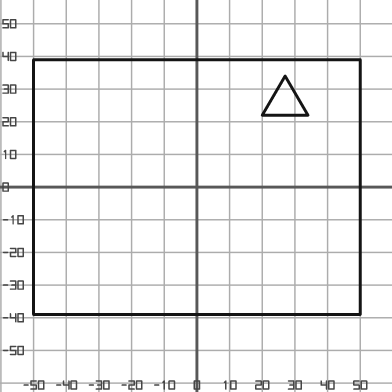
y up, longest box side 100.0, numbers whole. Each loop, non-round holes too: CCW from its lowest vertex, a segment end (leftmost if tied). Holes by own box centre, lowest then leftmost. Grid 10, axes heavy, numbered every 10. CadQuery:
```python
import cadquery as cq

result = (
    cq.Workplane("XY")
    .moveTo(-50.0, -39.0)
    .lineTo(50.0, -39.0)
    .lineTo(50.0, 39.0)
    .lineTo(-50.0, 39.0)
    .close()
    .moveTo(20.0, 22.0)
    .lineTo(34.0, 22.0)
    .lineTo(27.0, 34.0)
    .close()
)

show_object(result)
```